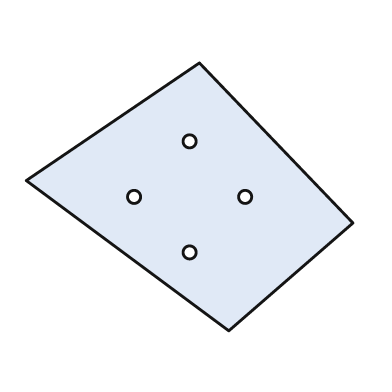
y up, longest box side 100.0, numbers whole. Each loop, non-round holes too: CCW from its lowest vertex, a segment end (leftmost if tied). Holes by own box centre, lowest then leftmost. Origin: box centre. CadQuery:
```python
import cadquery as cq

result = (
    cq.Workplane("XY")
    .moveTo(12.0, -41.0)
    .lineTo(50.0, -8.0)
    .lineTo(3.0, 41.0)
    .lineTo(-50.0, 5.0)
    .close()
    .moveTo(0.0, -17.0)
    .circle(2.0)
    .moveTo(-17.0, 0.0)
    .circle(2.0)
    .moveTo(17.0, 0.0)
    .circle(2.0)
    .moveTo(0.0, 17.0)
    .circle(2.0)
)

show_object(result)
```